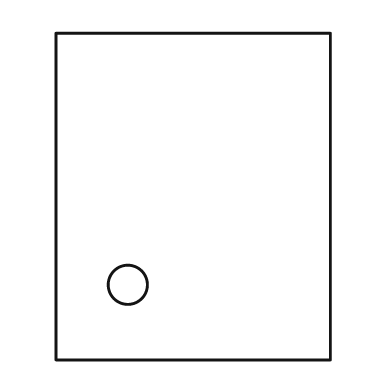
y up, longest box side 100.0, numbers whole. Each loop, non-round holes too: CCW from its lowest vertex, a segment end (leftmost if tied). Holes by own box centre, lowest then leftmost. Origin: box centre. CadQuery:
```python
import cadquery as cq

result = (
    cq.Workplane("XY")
    .moveTo(-42.0, -50.0)
    .lineTo(42.0, -50.0)
    .lineTo(42.0, 50.0)
    .lineTo(-42.0, 50.0)
    .close()
    .moveTo(-20.0, -27.0)
    .circle(6.0)
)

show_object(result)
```